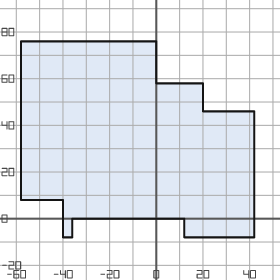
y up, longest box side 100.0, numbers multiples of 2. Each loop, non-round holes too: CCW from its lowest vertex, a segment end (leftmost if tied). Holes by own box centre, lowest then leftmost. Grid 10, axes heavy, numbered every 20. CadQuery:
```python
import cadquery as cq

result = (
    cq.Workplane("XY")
    .moveTo(-40.0, -8.0)
    .lineTo(-36.0, -8.0)
    .lineTo(-36.0, 0.0)
    .lineTo(12.0, 0.0)
    .lineTo(12.0, -8.0)
    .lineTo(42.0, -8.0)
    .lineTo(42.0, 46.0)
    .lineTo(20.0, 46.0)
    .lineTo(20.0, 58.0)
    .lineTo(0.0, 58.0)
    .lineTo(0.0, 76.0)
    .lineTo(-58.0, 76.0)
    .lineTo(-58.0, 8.0)
    .lineTo(-40.0, 8.0)
    .close()
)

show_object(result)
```